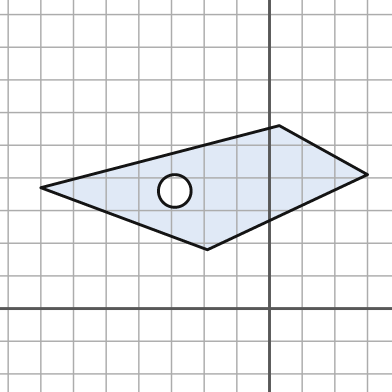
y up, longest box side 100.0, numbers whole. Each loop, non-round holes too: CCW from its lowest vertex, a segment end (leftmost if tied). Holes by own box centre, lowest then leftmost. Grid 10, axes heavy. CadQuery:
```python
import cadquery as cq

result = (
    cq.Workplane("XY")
    .moveTo(-19.0, 18.0)
    .lineTo(30.0, 41.0)
    .lineTo(3.0, 56.0)
    .lineTo(-70.0, 37.0)
    .close()
    .moveTo(-29.0, 36.0)
    .circle(5.0)
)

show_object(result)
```